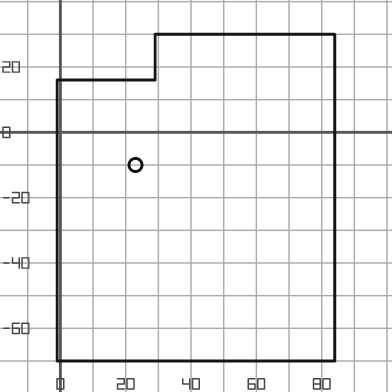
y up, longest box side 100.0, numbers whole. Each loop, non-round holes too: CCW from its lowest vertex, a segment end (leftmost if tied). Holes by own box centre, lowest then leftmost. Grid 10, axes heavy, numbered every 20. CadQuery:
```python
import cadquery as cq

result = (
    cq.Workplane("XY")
    .moveTo(-1.0, -70.0)
    .lineTo(84.0, -70.0)
    .lineTo(84.0, 30.0)
    .lineTo(29.0, 30.0)
    .lineTo(29.0, 16.0)
    .lineTo(-1.0, 16.0)
    .close()
    .moveTo(23.0, -10.0)
    .circle(2.0)
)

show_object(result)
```